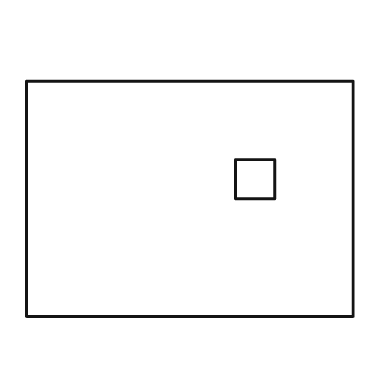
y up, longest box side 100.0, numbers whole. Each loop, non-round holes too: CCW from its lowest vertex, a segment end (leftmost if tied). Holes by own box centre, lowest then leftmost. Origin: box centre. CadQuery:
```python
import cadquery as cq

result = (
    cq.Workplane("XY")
    .moveTo(-50.0, -36.0)
    .lineTo(50.0, -36.0)
    .lineTo(50.0, 36.0)
    .lineTo(-50.0, 36.0)
    .close()
    .moveTo(14.0, 0.0)
    .lineTo(26.0, 0.0)
    .lineTo(26.0, 12.0)
    .lineTo(14.0, 12.0)
    .close()
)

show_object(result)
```